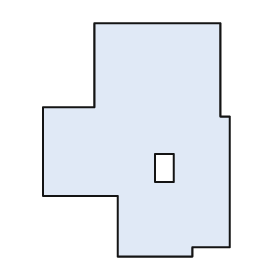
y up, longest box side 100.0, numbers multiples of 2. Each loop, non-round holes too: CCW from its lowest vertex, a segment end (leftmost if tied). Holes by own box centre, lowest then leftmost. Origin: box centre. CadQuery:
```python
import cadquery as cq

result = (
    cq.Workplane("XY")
    .moveTo(-8.0, -50.0)
    .lineTo(24.0, -50.0)
    .lineTo(24.0, -46.0)
    .lineTo(40.0, -46.0)
    .lineTo(40.0, 10.0)
    .lineTo(36.0, 10.0)
    .lineTo(36.0, 50.0)
    .lineTo(-18.0, 50.0)
    .lineTo(-18.0, 14.0)
    .lineTo(-40.0, 14.0)
    .lineTo(-40.0, -24.0)
    .lineTo(-8.0, -24.0)
    .close()
    .moveTo(8.0, -18.0)
    .lineTo(16.0, -18.0)
    .lineTo(16.0, -6.0)
    .lineTo(8.0, -6.0)
    .close()
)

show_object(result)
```